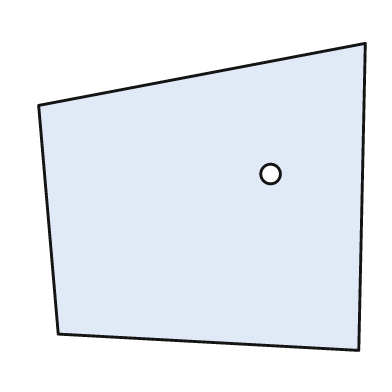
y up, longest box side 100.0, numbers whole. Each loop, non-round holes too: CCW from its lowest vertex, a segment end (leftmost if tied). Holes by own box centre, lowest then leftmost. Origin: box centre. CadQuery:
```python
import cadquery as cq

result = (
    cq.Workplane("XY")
    .moveTo(48.0, -47.0)
    .lineTo(50.0, 47.0)
    .lineTo(-50.0, 28.0)
    .lineTo(-44.0, -42.0)
    .close()
    .moveTo(21.0, 7.0)
    .circle(3.0)
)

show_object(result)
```